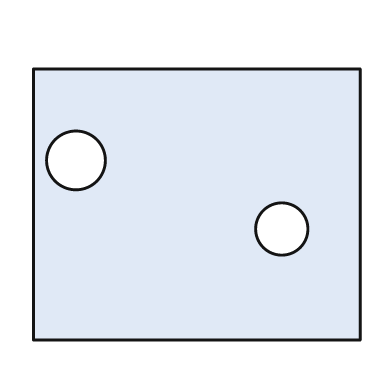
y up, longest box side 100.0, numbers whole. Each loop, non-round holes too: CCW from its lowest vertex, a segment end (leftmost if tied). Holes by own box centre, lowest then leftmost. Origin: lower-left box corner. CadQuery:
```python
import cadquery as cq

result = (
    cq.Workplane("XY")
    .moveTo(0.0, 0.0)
    .lineTo(100.0, 0.0)
    .lineTo(100.0, 83.0)
    .lineTo(0.0, 83.0)
    .close()
    .moveTo(76.0, 34.0)
    .circle(8.0)
    .moveTo(13.0, 55.0)
    .circle(9.0)
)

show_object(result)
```